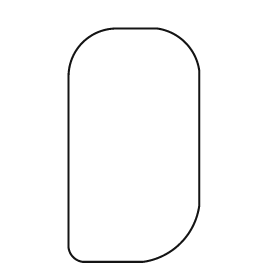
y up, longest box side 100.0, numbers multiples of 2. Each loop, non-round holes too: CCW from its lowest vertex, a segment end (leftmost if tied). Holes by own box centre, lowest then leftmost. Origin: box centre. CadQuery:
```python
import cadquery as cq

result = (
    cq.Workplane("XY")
    .moveTo(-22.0, -50.0)
    .lineTo(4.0, -50.0)
    .threePointArc((20.0, -42.0), (28.0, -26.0))
    .lineTo(28.0, 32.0)
    .threePointArc((22.0, 44.0), (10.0, 50.0))
    .lineTo(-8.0, 50.0)
    .threePointArc((-22.0, 44.0), (-28.0, 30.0))
    .lineTo(-28.0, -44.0)
    .threePointArc((-26.0, -48.0), (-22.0, -50.0))
    .close()
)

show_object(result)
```